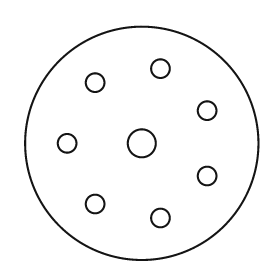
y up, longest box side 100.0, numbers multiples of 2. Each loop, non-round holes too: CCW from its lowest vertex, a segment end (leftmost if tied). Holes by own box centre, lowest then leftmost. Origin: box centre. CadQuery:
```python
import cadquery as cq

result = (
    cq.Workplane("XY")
    .moveTo(0.0, 0.0)
    .circle(50.0)
    .moveTo(8.0, -32.0)
    .circle(4.0)
    .moveTo(-20.0, -26.0)
    .circle(4.0)
    .moveTo(28.0, -14.0)
    .circle(4.0)
    .moveTo(-32.0, 0.0)
    .circle(4.0)
    .moveTo(0.0, 0.0)
    .circle(6.0)
    .moveTo(28.0, 14.0)
    .circle(4.0)
    .moveTo(-20.0, 26.0)
    .circle(4.0)
    .moveTo(8.0, 32.0)
    .circle(4.0)
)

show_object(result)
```